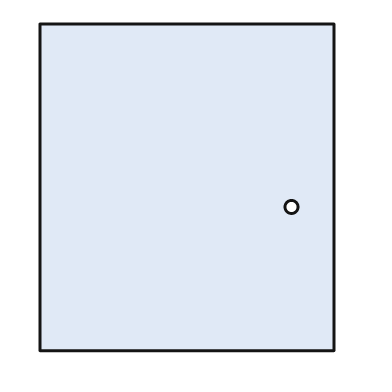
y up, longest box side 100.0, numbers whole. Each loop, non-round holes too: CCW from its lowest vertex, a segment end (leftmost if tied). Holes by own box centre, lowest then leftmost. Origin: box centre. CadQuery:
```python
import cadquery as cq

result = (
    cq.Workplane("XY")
    .moveTo(-45.0, -50.0)
    .lineTo(45.0, -50.0)
    .lineTo(45.0, 50.0)
    .lineTo(-45.0, 50.0)
    .close()
    .moveTo(32.0, -6.0)
    .circle(2.0)
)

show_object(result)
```